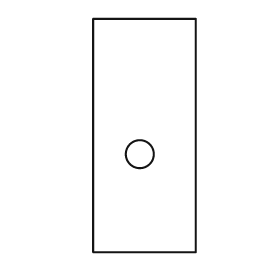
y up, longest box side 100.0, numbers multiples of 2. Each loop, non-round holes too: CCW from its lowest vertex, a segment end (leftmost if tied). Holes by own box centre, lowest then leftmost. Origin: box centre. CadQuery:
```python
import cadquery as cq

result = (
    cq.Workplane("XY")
    .moveTo(-22.0, -50.0)
    .lineTo(22.0, -50.0)
    .lineTo(22.0, 50.0)
    .lineTo(-22.0, 50.0)
    .close()
    .moveTo(-2.0, -8.0)
    .circle(6.0)
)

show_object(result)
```